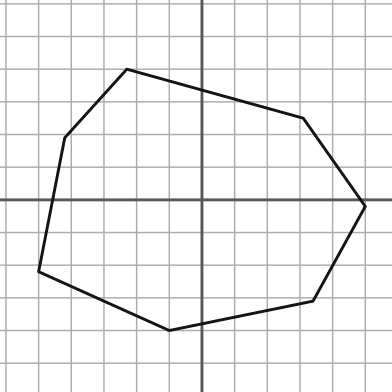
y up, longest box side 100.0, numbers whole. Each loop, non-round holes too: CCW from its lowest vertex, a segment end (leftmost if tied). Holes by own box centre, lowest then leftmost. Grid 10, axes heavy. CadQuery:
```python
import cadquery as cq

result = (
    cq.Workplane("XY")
    .moveTo(-10.0, -40.0)
    .lineTo(34.0, -31.0)
    .lineTo(50.0, -2.0)
    .lineTo(31.0, 25.0)
    .lineTo(-23.0, 40.0)
    .lineTo(-42.0, 19.0)
    .lineTo(-50.0, -22.0)
    .close()
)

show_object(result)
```